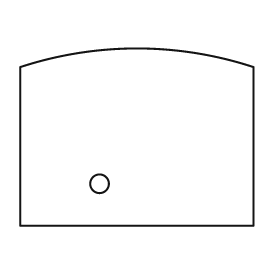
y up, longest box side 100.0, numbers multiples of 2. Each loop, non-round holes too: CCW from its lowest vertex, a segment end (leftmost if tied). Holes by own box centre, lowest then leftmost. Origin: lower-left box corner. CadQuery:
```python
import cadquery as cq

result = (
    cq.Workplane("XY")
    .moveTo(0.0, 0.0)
    .lineTo(100.0, 0.0)
    .lineTo(100.0, 68.0)
    .threePointArc((50.0, 76.0), (0.0, 68.0))
    .close()
    .moveTo(34.0, 18.0)
    .circle(4.0)
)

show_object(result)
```